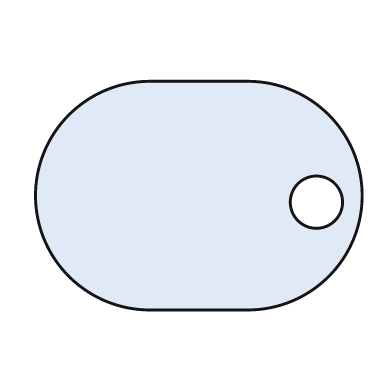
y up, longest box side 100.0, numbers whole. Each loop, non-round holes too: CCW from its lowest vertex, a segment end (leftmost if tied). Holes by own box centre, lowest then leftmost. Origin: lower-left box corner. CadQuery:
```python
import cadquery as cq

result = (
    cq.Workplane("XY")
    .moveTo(35.0, 0.0)
    .lineTo(65.0, 0.0)
    .threePointArc((100.0, 35.0), (65.0, 70.0))
    .lineTo(35.0, 70.0)
    .threePointArc((0.0, 35.0), (35.0, 0.0))
    .close()
    .moveTo(86.0, 33.0)
    .circle(8.0)
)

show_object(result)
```